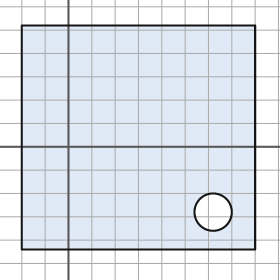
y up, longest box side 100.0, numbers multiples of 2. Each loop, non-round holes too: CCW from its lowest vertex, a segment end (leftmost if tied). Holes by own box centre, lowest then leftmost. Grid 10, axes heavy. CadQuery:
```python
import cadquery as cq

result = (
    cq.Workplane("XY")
    .moveTo(-20.0, -44.0)
    .lineTo(80.0, -44.0)
    .lineTo(80.0, 52.0)
    .lineTo(-20.0, 52.0)
    .close()
    .moveTo(62.0, -28.0)
    .circle(8.0)
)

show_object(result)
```